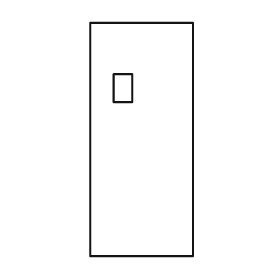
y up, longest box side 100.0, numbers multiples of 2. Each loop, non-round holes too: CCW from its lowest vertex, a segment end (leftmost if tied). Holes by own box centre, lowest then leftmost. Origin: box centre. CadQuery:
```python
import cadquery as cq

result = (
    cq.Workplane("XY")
    .moveTo(-22.0, -50.0)
    .lineTo(22.0, -50.0)
    .lineTo(22.0, 50.0)
    .lineTo(-22.0, 50.0)
    .close()
    .moveTo(-12.0, 16.0)
    .lineTo(-4.0, 16.0)
    .lineTo(-4.0, 28.0)
    .lineTo(-12.0, 28.0)
    .close()
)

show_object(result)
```